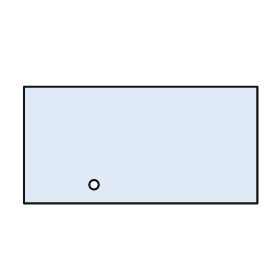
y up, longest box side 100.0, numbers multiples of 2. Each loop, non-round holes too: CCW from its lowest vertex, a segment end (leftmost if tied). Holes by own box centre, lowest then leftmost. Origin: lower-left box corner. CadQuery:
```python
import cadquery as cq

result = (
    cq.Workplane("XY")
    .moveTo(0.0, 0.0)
    .lineTo(100.0, 0.0)
    .lineTo(100.0, 50.0)
    .lineTo(0.0, 50.0)
    .close()
    .moveTo(30.0, 8.0)
    .circle(2.0)
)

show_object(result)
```